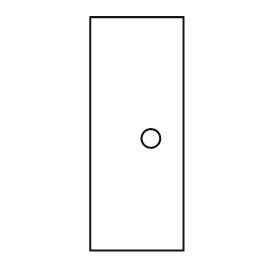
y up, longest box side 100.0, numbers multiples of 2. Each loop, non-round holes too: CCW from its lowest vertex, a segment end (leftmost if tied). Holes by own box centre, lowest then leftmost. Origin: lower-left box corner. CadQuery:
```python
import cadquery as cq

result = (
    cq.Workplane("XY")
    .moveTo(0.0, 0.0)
    .lineTo(40.0, 0.0)
    .lineTo(40.0, 100.0)
    .lineTo(0.0, 100.0)
    .close()
    .moveTo(26.0, 48.0)
    .circle(4.0)
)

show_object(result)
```